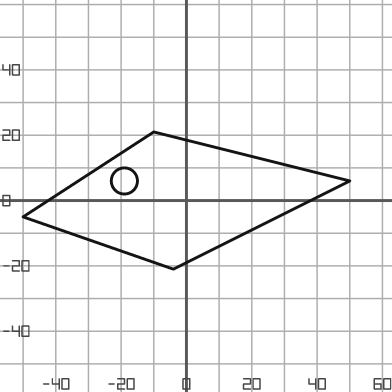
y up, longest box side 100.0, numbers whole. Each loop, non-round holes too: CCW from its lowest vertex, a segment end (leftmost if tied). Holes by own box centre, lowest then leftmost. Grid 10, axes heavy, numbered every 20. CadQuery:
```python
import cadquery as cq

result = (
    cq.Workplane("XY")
    .moveTo(-4.0, -21.0)
    .lineTo(50.0, 6.0)
    .lineTo(-10.0, 21.0)
    .lineTo(-50.0, -5.0)
    .close()
    .moveTo(-19.0, 6.0)
    .circle(4.0)
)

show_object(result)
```